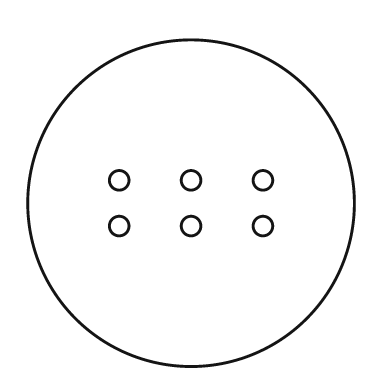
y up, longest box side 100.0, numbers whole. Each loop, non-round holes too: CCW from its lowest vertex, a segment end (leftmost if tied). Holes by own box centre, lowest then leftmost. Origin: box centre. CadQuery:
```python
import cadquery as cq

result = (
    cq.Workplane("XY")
    .moveTo(0.0, 0.0)
    .circle(50.0)
    .moveTo(-22.0, -7.0)
    .circle(3.0)
    .moveTo(0.0, -7.0)
    .circle(3.0)
    .moveTo(22.0, -7.0)
    .circle(3.0)
    .moveTo(-22.0, 7.0)
    .circle(3.0)
    .moveTo(0.0, 7.0)
    .circle(3.0)
    .moveTo(22.0, 7.0)
    .circle(3.0)
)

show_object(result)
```